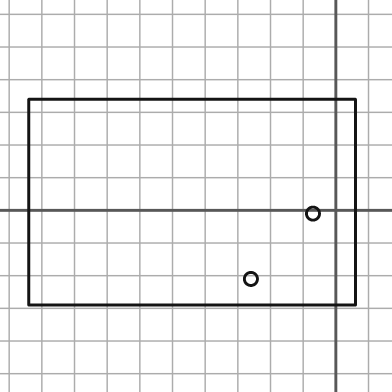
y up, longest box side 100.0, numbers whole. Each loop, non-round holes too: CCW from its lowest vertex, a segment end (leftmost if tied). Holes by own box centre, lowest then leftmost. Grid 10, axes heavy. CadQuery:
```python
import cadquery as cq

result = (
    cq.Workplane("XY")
    .moveTo(-94.0, -29.0)
    .lineTo(6.0, -29.0)
    .lineTo(6.0, 34.0)
    .lineTo(-94.0, 34.0)
    .close()
    .moveTo(-26.0, -21.0)
    .circle(2.0)
    .moveTo(-7.0, -1.0)
    .circle(2.0)
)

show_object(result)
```